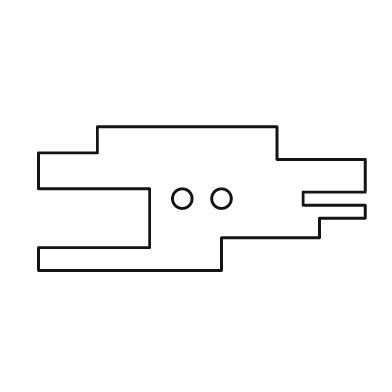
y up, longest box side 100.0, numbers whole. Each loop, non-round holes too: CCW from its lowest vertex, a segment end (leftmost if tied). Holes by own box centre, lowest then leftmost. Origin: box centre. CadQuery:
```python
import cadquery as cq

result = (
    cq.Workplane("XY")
    .moveTo(-50.0, -22.0)
    .lineTo(6.0, -22.0)
    .lineTo(6.0, -12.0)
    .lineTo(36.0, -12.0)
    .lineTo(36.0, -6.0)
    .lineTo(50.0, -6.0)
    .lineTo(50.0, -2.0)
    .lineTo(31.0, -2.0)
    .lineTo(31.0, 2.0)
    .lineTo(50.0, 2.0)
    .lineTo(50.0, 12.0)
    .lineTo(23.0, 12.0)
    .lineTo(23.0, 22.0)
    .lineTo(-32.0, 22.0)
    .lineTo(-32.0, 14.0)
    .lineTo(-50.0, 14.0)
    .lineTo(-50.0, 3.0)
    .lineTo(-16.0, 3.0)
    .lineTo(-16.0, -15.0)
    .lineTo(-50.0, -15.0)
    .close()
    .moveTo(-6.0, 0.0)
    .circle(3.0)
    .moveTo(6.0, 0.0)
    .circle(3.0)
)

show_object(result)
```